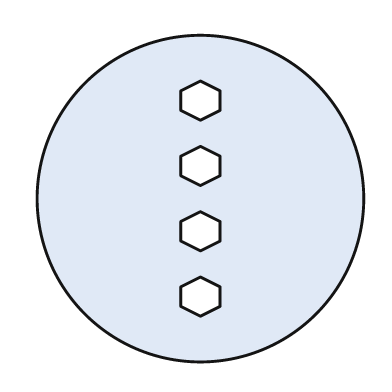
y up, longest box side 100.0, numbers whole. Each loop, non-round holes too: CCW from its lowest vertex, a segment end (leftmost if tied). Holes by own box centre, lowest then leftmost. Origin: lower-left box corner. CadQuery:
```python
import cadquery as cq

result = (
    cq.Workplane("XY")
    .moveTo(50.0, 50.0)
    .circle(50.0)
    .moveTo(50.0, 14.0)
    .lineTo(56.0, 17.0)
    .lineTo(56.0, 23.0)
    .lineTo(50.0, 26.0)
    .lineTo(44.0, 23.0)
    .lineTo(44.0, 17.0)
    .close()
    .moveTo(50.0, 34.0)
    .lineTo(56.0, 37.0)
    .lineTo(56.0, 43.0)
    .lineTo(50.0, 46.0)
    .lineTo(44.0, 43.0)
    .lineTo(44.0, 37.0)
    .close()
    .moveTo(50.0, 54.0)
    .lineTo(56.0, 57.0)
    .lineTo(56.0, 63.0)
    .lineTo(50.0, 66.0)
    .lineTo(44.0, 63.0)
    .lineTo(44.0, 57.0)
    .close()
    .moveTo(50.0, 74.0)
    .lineTo(56.0, 77.0)
    .lineTo(56.0, 83.0)
    .lineTo(50.0, 86.0)
    .lineTo(44.0, 83.0)
    .lineTo(44.0, 77.0)
    .close()
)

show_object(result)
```